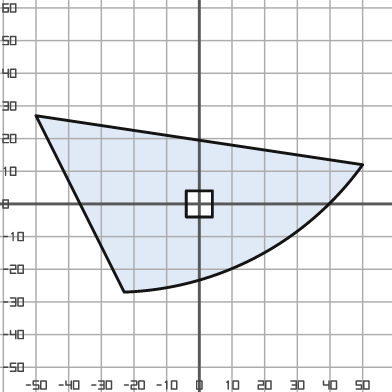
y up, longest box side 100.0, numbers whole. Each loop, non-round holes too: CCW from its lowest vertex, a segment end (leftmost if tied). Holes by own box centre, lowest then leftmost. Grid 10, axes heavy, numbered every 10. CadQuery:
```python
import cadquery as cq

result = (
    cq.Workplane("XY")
    .moveTo(-23.0, -27.0)
    .threePointArc((18.0, -16.0), (50.0, 12.0))
    .lineTo(-50.0, 27.0)
    .close()
    .moveTo(-4.0, -4.0)
    .lineTo(4.0, -4.0)
    .lineTo(4.0, 4.0)
    .lineTo(-4.0, 4.0)
    .close()
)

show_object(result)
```